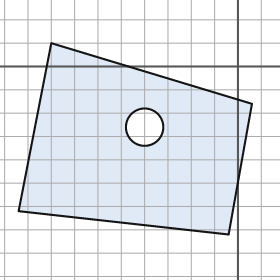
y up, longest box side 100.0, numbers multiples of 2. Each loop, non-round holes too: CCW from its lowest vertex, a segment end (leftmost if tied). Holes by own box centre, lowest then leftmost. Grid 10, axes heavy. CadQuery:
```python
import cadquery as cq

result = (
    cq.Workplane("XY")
    .moveTo(-4.0, -72.0)
    .lineTo(6.0, -16.0)
    .lineTo(-80.0, 10.0)
    .lineTo(-94.0, -62.0)
    .close()
    .moveTo(-40.0, -26.0)
    .circle(8.0)
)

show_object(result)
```